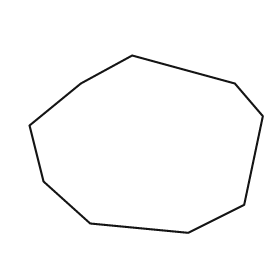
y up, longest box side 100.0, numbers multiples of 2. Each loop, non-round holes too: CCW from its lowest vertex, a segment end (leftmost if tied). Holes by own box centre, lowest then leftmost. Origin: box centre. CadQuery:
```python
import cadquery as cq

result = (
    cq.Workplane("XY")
    .moveTo(18.0, -38.0)
    .lineTo(42.0, -26.0)
    .lineTo(50.0, 12.0)
    .lineTo(38.0, 26.0)
    .lineTo(-6.0, 38.0)
    .lineTo(-28.0, 26.0)
    .lineTo(-50.0, 8.0)
    .lineTo(-44.0, -16.0)
    .lineTo(-24.0, -34.0)
    .close()
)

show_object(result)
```